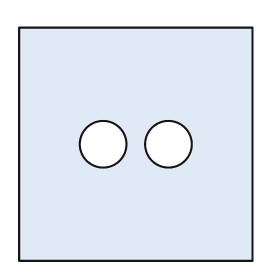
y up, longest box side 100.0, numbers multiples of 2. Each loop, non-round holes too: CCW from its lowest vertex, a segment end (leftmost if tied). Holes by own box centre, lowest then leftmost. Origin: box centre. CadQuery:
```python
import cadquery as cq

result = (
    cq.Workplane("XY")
    .moveTo(-50.0, -50.0)
    .lineTo(50.0, -50.0)
    .lineTo(50.0, 50.0)
    .lineTo(-50.0, 50.0)
    .close()
    .moveTo(-14.0, 0.0)
    .circle(10.0)
    .moveTo(14.0, 0.0)
    .circle(10.0)
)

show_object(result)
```